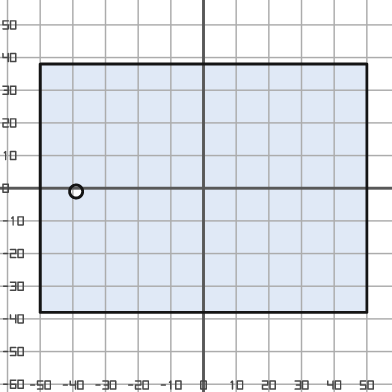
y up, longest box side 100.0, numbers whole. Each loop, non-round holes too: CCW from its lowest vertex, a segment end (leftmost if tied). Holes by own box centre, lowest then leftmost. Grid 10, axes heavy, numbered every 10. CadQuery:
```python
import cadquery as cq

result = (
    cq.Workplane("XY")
    .moveTo(-50.0, -38.0)
    .lineTo(50.0, -38.0)
    .lineTo(50.0, 38.0)
    .lineTo(-50.0, 38.0)
    .close()
    .moveTo(-39.0, -1.0)
    .circle(2.0)
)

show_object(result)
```